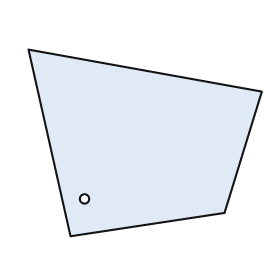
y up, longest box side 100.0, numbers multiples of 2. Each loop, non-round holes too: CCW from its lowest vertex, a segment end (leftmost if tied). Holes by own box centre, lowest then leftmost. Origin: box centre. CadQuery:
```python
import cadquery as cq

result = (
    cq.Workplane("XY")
    .moveTo(-32.0, -40.0)
    .lineTo(34.0, -30.0)
    .lineTo(50.0, 22.0)
    .lineTo(-50.0, 40.0)
    .close()
    .moveTo(-26.0, -24.0)
    .circle(2.0)
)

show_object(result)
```